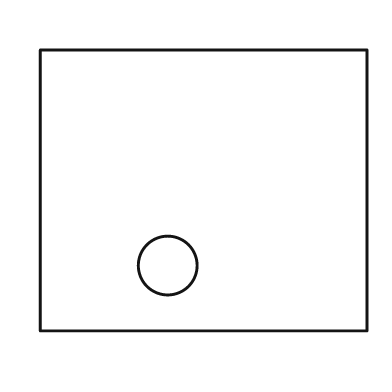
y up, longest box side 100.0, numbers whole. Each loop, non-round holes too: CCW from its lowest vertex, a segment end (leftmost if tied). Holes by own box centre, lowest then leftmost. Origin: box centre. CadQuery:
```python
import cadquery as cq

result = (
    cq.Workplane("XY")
    .moveTo(-50.0, -43.0)
    .lineTo(50.0, -43.0)
    .lineTo(50.0, 43.0)
    .lineTo(-50.0, 43.0)
    .close()
    .moveTo(-11.0, -23.0)
    .circle(9.0)
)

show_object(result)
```